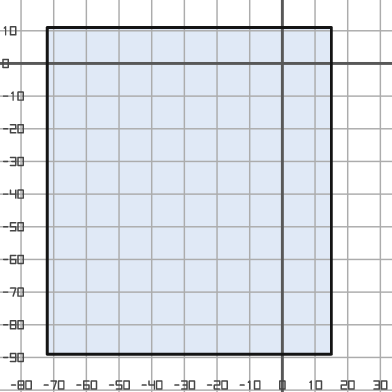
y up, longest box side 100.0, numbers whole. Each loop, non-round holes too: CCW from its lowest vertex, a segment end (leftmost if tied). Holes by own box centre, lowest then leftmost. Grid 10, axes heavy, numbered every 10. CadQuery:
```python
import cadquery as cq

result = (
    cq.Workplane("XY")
    .moveTo(-72.0, -89.0)
    .lineTo(15.0, -89.0)
    .lineTo(15.0, 11.0)
    .lineTo(-72.0, 11.0)
    .close()
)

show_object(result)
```